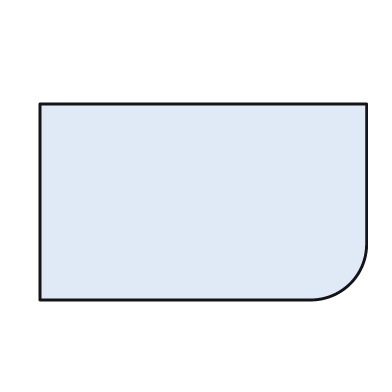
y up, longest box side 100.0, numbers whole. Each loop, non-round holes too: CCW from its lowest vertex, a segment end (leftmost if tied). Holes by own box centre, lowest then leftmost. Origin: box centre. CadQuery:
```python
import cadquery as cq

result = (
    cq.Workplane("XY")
    .moveTo(-50.0, -30.0)
    .lineTo(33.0, -30.0)
    .threePointArc((45.0, -25.0), (50.0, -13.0))
    .lineTo(50.0, 30.0)
    .lineTo(-50.0, 30.0)
    .close()
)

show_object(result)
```